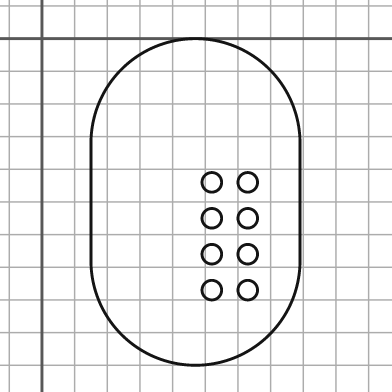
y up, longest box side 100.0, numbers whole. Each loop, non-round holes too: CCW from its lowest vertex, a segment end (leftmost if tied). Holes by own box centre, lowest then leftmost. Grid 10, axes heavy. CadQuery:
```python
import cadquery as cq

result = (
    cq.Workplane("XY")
    .moveTo(15.0, -68.0)
    .threePointArc((47.0, -100.0), (79.0, -68.0))
    .lineTo(79.0, -32.0)
    .threePointArc((47.0, 0.0), (15.0, -32.0))
    .close()
    .moveTo(52.0, -77.0)
    .circle(3.0)
    .moveTo(63.0, -77.0)
    .circle(3.0)
    .moveTo(52.0, -66.0)
    .circle(3.0)
    .moveTo(63.0, -66.0)
    .circle(3.0)
    .moveTo(52.0, -55.0)
    .circle(3.0)
    .moveTo(63.0, -55.0)
    .circle(3.0)
    .moveTo(52.0, -44.0)
    .circle(3.0)
    .moveTo(63.0, -44.0)
    .circle(3.0)
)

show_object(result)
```